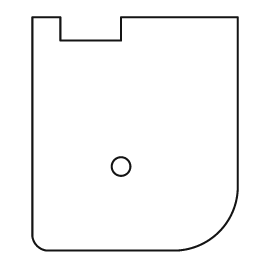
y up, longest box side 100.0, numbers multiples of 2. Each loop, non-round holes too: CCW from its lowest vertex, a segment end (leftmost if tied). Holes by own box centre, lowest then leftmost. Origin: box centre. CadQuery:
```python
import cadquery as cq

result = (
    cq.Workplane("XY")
    .moveTo(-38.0, -50.0)
    .lineTo(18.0, -50.0)
    .threePointArc((36.0, -42.0), (44.0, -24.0))
    .lineTo(44.0, 50.0)
    .lineTo(-6.0, 50.0)
    .lineTo(-6.0, 40.0)
    .lineTo(-32.0, 40.0)
    .lineTo(-32.0, 50.0)
    .lineTo(-44.0, 50.0)
    .lineTo(-44.0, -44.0)
    .threePointArc((-42.0, -48.0), (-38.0, -50.0))
    .close()
    .moveTo(-6.0, -14.0)
    .circle(4.0)
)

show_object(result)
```